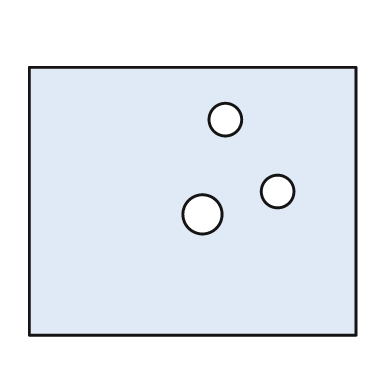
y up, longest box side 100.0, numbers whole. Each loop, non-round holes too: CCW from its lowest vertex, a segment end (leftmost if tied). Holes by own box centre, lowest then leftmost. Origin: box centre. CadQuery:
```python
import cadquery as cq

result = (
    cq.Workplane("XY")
    .moveTo(-50.0, -41.0)
    .lineTo(50.0, -41.0)
    .lineTo(50.0, 41.0)
    .lineTo(-50.0, 41.0)
    .close()
    .moveTo(3.0, -4.0)
    .circle(6.0)
    .moveTo(26.0, 3.0)
    .circle(5.0)
    .moveTo(10.0, 25.0)
    .circle(5.0)
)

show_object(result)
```